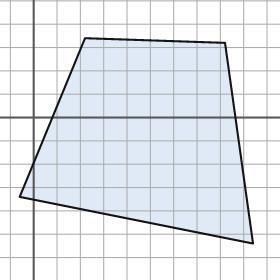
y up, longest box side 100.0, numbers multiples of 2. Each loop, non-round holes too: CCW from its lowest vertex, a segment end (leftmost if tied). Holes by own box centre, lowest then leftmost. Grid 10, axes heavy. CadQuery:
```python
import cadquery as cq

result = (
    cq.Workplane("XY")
    .moveTo(94.0, -54.0)
    .lineTo(82.0, 32.0)
    .lineTo(22.0, 34.0)
    .lineTo(-6.0, -34.0)
    .close()
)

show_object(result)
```